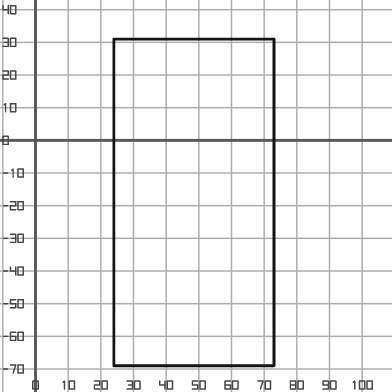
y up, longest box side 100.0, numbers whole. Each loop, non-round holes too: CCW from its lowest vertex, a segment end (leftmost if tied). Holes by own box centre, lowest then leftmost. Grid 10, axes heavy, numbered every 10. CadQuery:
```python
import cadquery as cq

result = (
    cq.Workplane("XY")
    .moveTo(24.0, -69.0)
    .lineTo(73.0, -69.0)
    .lineTo(73.0, 31.0)
    .lineTo(24.0, 31.0)
    .close()
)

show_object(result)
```